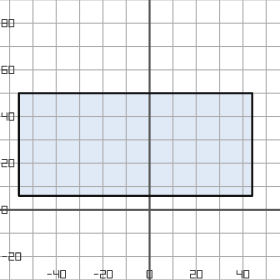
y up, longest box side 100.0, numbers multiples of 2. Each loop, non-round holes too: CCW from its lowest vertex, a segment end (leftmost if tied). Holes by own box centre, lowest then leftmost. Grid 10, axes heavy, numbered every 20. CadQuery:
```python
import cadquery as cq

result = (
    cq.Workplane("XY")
    .moveTo(-56.0, 6.0)
    .lineTo(44.0, 6.0)
    .lineTo(44.0, 50.0)
    .lineTo(-56.0, 50.0)
    .close()
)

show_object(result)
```